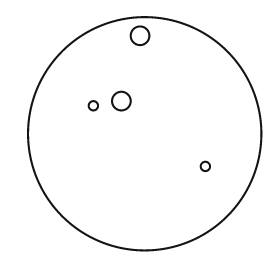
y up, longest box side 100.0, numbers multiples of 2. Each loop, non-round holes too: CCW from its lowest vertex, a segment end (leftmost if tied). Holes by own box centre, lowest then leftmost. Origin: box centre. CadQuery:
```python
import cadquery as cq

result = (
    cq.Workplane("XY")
    .moveTo(0.0, 0.0)
    .circle(50.0)
    .moveTo(26.0, -14.0)
    .circle(2.0)
    .moveTo(-22.0, 12.0)
    .circle(2.0)
    .moveTo(-10.0, 14.0)
    .circle(4.0)
    .moveTo(-2.0, 42.0)
    .circle(4.0)
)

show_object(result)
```